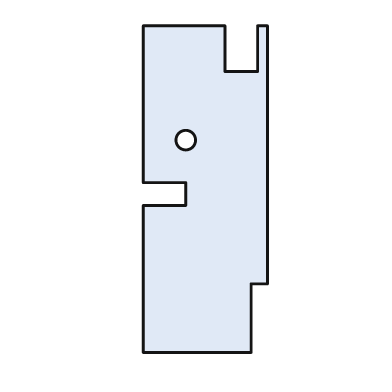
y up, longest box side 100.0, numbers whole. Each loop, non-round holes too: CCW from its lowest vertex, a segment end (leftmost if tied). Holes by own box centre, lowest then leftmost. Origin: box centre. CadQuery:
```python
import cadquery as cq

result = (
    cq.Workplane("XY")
    .moveTo(-19.0, -50.0)
    .lineTo(14.0, -50.0)
    .lineTo(14.0, -29.0)
    .lineTo(19.0, -29.0)
    .lineTo(19.0, 50.0)
    .lineTo(16.0, 50.0)
    .lineTo(16.0, 36.0)
    .lineTo(6.0, 36.0)
    .lineTo(6.0, 50.0)
    .lineTo(-19.0, 50.0)
    .lineTo(-19.0, 2.0)
    .lineTo(-6.0, 2.0)
    .lineTo(-6.0, -5.0)
    .lineTo(-19.0, -5.0)
    .close()
    .moveTo(-6.0, 15.0)
    .circle(3.0)
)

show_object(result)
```